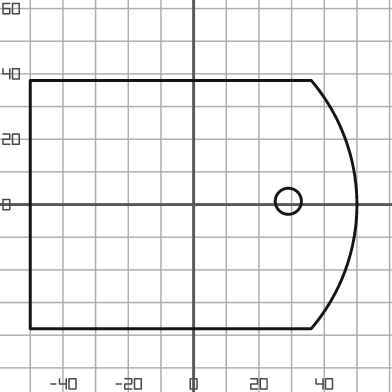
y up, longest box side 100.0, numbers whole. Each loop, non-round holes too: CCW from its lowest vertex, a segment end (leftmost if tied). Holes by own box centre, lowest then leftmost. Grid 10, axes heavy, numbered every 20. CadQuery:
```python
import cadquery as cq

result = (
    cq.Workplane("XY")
    .moveTo(-50.0, -38.0)
    .lineTo(36.0, -38.0)
    .threePointArc((50.0, 0.0), (36.0, 38.0))
    .lineTo(-50.0, 38.0)
    .close()
    .moveTo(29.0, 1.0)
    .circle(4.0)
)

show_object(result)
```